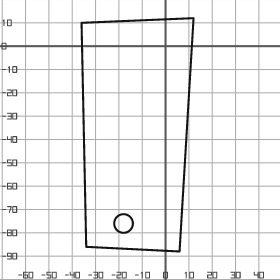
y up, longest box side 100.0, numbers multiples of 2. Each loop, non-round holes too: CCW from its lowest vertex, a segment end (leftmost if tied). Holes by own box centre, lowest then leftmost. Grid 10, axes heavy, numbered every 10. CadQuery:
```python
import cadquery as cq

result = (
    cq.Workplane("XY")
    .moveTo(6.0, -88.0)
    .lineTo(12.0, 12.0)
    .lineTo(-36.0, 10.0)
    .lineTo(-34.0, -86.0)
    .close()
    .moveTo(-18.0, -76.0)
    .circle(4.0)
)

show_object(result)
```